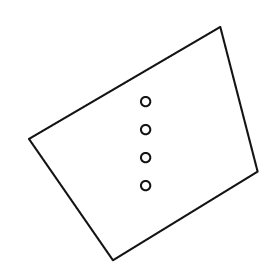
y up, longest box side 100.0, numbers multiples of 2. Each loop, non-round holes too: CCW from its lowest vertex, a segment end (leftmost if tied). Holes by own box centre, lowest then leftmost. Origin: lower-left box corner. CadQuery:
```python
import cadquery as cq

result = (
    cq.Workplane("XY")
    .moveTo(36.0, 0.0)
    .lineTo(98.0, 38.0)
    .lineTo(82.0, 100.0)
    .lineTo(0.0, 52.0)
    .close()
    .moveTo(50.0, 32.0)
    .circle(2.0)
    .moveTo(50.0, 44.0)
    .circle(2.0)
    .moveTo(50.0, 56.0)
    .circle(2.0)
    .moveTo(50.0, 68.0)
    .circle(2.0)
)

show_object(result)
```